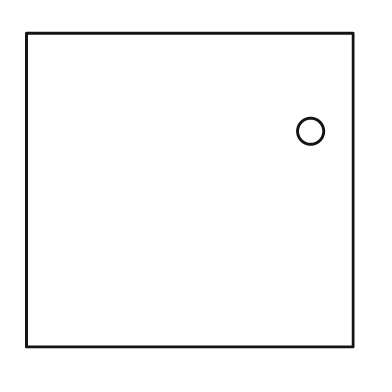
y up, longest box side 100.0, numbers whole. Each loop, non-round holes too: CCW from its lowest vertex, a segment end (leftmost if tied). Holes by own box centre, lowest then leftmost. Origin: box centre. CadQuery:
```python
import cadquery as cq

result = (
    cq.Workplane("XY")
    .moveTo(-50.0, -48.0)
    .lineTo(50.0, -48.0)
    .lineTo(50.0, 48.0)
    .lineTo(-50.0, 48.0)
    .close()
    .moveTo(37.0, 18.0)
    .circle(4.0)
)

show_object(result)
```